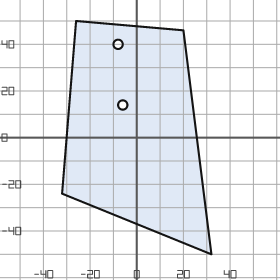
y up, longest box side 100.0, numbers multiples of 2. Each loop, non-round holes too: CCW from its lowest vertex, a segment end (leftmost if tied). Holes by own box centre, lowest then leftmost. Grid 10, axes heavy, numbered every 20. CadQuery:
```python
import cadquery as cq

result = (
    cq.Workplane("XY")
    .moveTo(32.0, -50.0)
    .lineTo(20.0, 46.0)
    .lineTo(-26.0, 50.0)
    .lineTo(-32.0, -24.0)
    .close()
    .moveTo(-6.0, 14.0)
    .circle(2.0)
    .moveTo(-8.0, 40.0)
    .circle(2.0)
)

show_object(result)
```